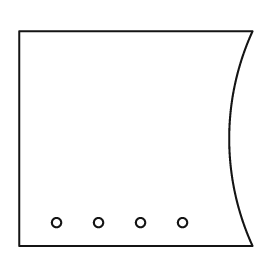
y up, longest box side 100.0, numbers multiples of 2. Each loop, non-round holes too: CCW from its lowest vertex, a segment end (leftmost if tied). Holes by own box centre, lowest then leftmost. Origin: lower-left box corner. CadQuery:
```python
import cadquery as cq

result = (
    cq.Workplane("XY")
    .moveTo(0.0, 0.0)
    .lineTo(100.0, 0.0)
    .threePointArc((90.0, 46.0), (100.0, 92.0))
    .lineTo(0.0, 92.0)
    .close()
    .moveTo(16.0, 10.0)
    .circle(2.0)
    .moveTo(34.0, 10.0)
    .circle(2.0)
    .moveTo(52.0, 10.0)
    .circle(2.0)
    .moveTo(70.0, 10.0)
    .circle(2.0)
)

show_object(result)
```